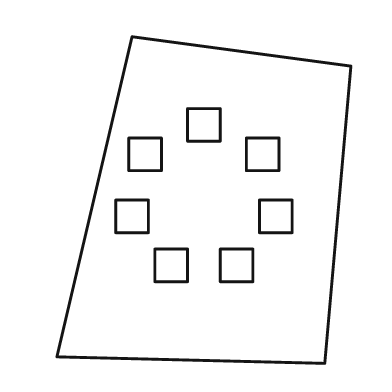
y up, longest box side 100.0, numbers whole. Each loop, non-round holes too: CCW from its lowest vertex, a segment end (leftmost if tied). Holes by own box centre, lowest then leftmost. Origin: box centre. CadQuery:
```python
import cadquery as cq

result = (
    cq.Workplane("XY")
    .moveTo(37.0, -50.0)
    .lineTo(45.0, 41.0)
    .lineTo(-22.0, 50.0)
    .lineTo(-45.0, -48.0)
    .close()
    .moveTo(-15.0, -25.0)
    .lineTo(-5.0, -25.0)
    .lineTo(-5.0, -15.0)
    .lineTo(-15.0, -15.0)
    .close()
    .moveTo(5.0, -25.0)
    .lineTo(15.0, -25.0)
    .lineTo(15.0, -15.0)
    .lineTo(5.0, -15.0)
    .close()
    .moveTo(-27.0, -10.0)
    .lineTo(-17.0, -10.0)
    .lineTo(-17.0, 0.0)
    .lineTo(-27.0, 0.0)
    .close()
    .moveTo(17.0, -10.0)
    .lineTo(27.0, -10.0)
    .lineTo(27.0, 0.0)
    .lineTo(17.0, 0.0)
    .close()
    .moveTo(-23.0, 9.0)
    .lineTo(-13.0, 9.0)
    .lineTo(-13.0, 19.0)
    .lineTo(-23.0, 19.0)
    .close()
    .moveTo(13.0, 9.0)
    .lineTo(23.0, 9.0)
    .lineTo(23.0, 19.0)
    .lineTo(13.0, 19.0)
    .close()
    .moveTo(-5.0, 18.0)
    .lineTo(5.0, 18.0)
    .lineTo(5.0, 28.0)
    .lineTo(-5.0, 28.0)
    .close()
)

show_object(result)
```